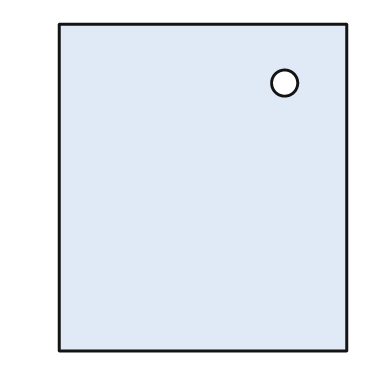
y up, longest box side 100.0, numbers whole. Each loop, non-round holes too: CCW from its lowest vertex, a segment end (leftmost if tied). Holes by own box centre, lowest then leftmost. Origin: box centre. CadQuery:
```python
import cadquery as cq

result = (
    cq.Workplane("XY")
    .moveTo(-44.0, -50.0)
    .lineTo(44.0, -50.0)
    .lineTo(44.0, 50.0)
    .lineTo(-44.0, 50.0)
    .close()
    .moveTo(25.0, 32.0)
    .circle(4.0)
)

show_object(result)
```